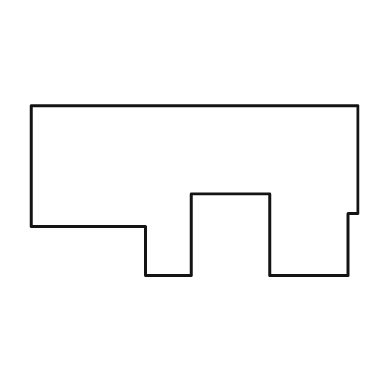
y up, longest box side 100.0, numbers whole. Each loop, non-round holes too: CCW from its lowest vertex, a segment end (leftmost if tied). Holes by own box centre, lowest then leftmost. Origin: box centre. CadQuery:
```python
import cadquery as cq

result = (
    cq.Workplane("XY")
    .moveTo(-15.0, -26.0)
    .lineTo(-1.0, -26.0)
    .lineTo(-1.0, -1.0)
    .lineTo(23.0, -1.0)
    .lineTo(23.0, -26.0)
    .lineTo(47.0, -26.0)
    .lineTo(47.0, -7.0)
    .lineTo(50.0, -7.0)
    .lineTo(50.0, 26.0)
    .lineTo(-50.0, 26.0)
    .lineTo(-50.0, -11.0)
    .lineTo(-15.0, -11.0)
    .close()
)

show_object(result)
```